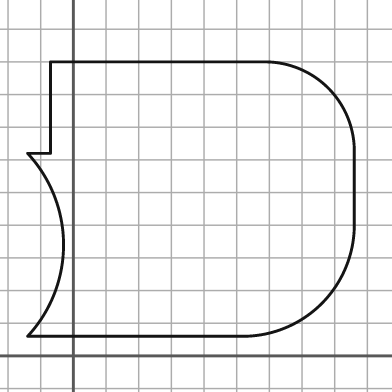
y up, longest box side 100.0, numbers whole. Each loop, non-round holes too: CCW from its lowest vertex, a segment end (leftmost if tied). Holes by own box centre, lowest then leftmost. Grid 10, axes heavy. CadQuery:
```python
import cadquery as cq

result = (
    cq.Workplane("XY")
    .moveTo(-14.0, 6.0)
    .lineTo(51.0, 6.0)
    .threePointArc((76.0, 16.0), (86.0, 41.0))
    .lineTo(86.0, 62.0)
    .threePointArc((78.0, 82.0), (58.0, 90.0))
    .lineTo(-7.0, 90.0)
    .lineTo(-7.0, 62.0)
    .lineTo(-14.0, 62.0)
    .threePointArc((-3.0, 34.0), (-14.0, 6.0))
    .close()
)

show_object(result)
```